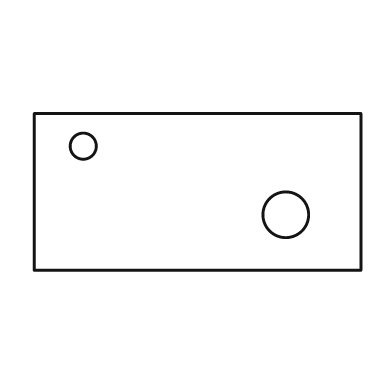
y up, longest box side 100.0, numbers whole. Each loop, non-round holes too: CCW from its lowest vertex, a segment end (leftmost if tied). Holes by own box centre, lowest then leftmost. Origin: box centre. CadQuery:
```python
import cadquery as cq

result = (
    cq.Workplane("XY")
    .moveTo(-50.0, -24.0)
    .lineTo(50.0, -24.0)
    .lineTo(50.0, 24.0)
    .lineTo(-50.0, 24.0)
    .close()
    .moveTo(27.0, -7.0)
    .circle(7.0)
    .moveTo(-35.0, 14.0)
    .circle(4.0)
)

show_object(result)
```